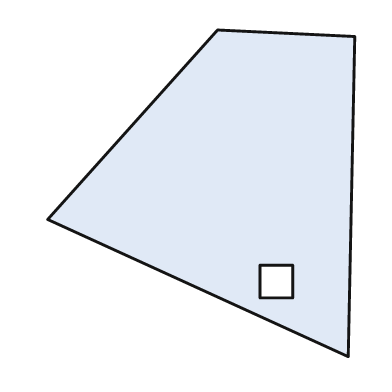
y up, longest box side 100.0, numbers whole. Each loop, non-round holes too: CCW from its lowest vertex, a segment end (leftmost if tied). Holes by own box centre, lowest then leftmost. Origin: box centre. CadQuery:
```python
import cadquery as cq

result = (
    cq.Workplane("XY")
    .moveTo(45.0, -50.0)
    .lineTo(47.0, 48.0)
    .lineTo(5.0, 50.0)
    .lineTo(-47.0, -8.0)
    .close()
    .moveTo(18.0, -32.0)
    .lineTo(28.0, -32.0)
    .lineTo(28.0, -22.0)
    .lineTo(18.0, -22.0)
    .close()
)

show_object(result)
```